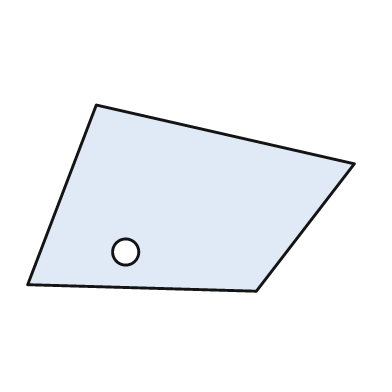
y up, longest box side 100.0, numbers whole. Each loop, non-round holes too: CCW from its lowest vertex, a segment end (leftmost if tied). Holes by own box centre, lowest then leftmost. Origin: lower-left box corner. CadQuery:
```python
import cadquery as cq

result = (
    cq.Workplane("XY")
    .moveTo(70.0, 0.0)
    .lineTo(100.0, 39.0)
    .lineTo(21.0, 57.0)
    .lineTo(0.0, 2.0)
    .close()
    .moveTo(30.0, 12.0)
    .circle(4.0)
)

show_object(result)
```